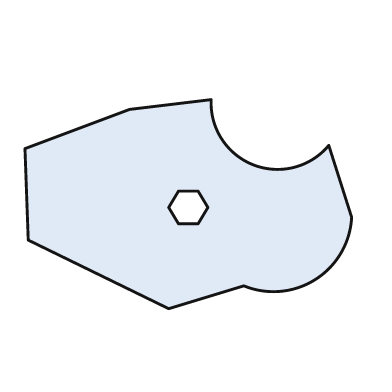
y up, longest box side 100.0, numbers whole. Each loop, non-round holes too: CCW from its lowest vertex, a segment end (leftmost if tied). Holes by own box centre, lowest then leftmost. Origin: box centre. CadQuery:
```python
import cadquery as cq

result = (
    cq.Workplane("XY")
    .moveTo(-6.0, -32.0)
    .lineTo(17.0, -25.0)
    .threePointArc((39.0, -23.0), (50.0, -4.0))
    .lineTo(43.0, 18.0)
    .threePointArc((20.0, 12.0), (7.0, 32.0))
    .lineTo(-18.0, 29.0)
    .lineTo(-50.0, 17.0)
    .lineTo(-49.0, -11.0)
    .close()
    .moveTo(-3.0, -6.0)
    .lineTo(3.0, -6.0)
    .lineTo(6.0, -1.0)
    .lineTo(3.0, 4.0)
    .lineTo(-3.0, 4.0)
    .lineTo(-6.0, -1.0)
    .close()
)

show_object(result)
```